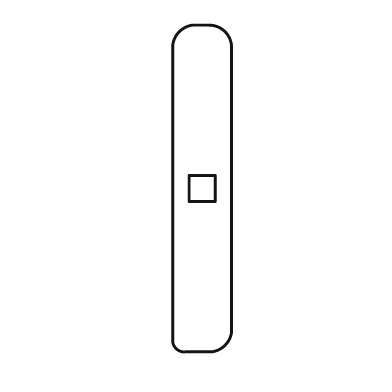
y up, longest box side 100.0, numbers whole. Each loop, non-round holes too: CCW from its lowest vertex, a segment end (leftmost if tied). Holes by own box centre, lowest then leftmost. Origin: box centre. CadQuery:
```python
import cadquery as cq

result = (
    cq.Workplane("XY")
    .moveTo(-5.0, -50.0)
    .lineTo(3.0, -50.0)
    .threePointArc((7.0, -48.0), (9.0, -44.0))
    .lineTo(9.0, 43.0)
    .threePointArc((7.0, 48.0), (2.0, 50.0))
    .lineTo(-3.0, 50.0)
    .threePointArc((-7.0, 48.0), (-9.0, 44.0))
    .lineTo(-9.0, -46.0)
    .threePointArc((-8.0, -49.0), (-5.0, -50.0))
    .close()
    .moveTo(-4.0, -4.0)
    .lineTo(4.0, -4.0)
    .lineTo(4.0, 4.0)
    .lineTo(-4.0, 4.0)
    .close()
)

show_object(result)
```